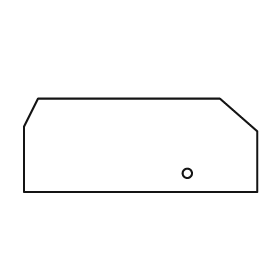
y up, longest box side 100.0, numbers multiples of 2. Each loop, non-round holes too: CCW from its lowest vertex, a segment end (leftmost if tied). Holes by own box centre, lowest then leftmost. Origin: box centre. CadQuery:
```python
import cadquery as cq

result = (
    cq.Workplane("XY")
    .moveTo(-50.0, -20.0)
    .lineTo(50.0, -20.0)
    .lineTo(50.0, 6.0)
    .lineTo(34.0, 20.0)
    .lineTo(-44.0, 20.0)
    .lineTo(-50.0, 8.0)
    .close()
    .moveTo(20.0, -12.0)
    .circle(2.0)
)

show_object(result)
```